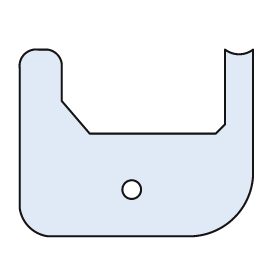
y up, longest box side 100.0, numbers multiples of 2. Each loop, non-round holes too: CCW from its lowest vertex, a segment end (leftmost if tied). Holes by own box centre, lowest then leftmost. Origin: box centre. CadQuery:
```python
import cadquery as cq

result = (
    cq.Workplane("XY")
    .moveTo(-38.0, -40.0)
    .lineTo(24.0, -40.0)
    .threePointArc((42.0, -32.0), (50.0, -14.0))
    .lineTo(50.0, 40.0)
    .threePointArc((44.0, 38.0), (38.0, 40.0))
    .lineTo(38.0, 8.0)
    .lineTo(34.0, 4.0)
    .lineTo(-20.0, 4.0)
    .lineTo(-32.0, 18.0)
    .lineTo(-32.0, 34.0)
    .threePointArc((-34.0, 38.0), (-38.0, 40.0))
    .lineTo(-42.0, 40.0)
    .threePointArc((-48.0, 38.0), (-50.0, 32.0))
    .lineTo(-50.0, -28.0)
    .threePointArc((-46.0, -36.0), (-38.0, -40.0))
    .close()
    .moveTo(-2.0, -20.0)
    .circle(4.0)
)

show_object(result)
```